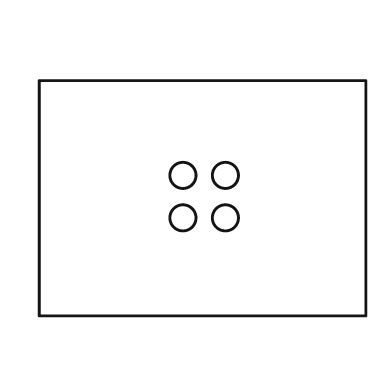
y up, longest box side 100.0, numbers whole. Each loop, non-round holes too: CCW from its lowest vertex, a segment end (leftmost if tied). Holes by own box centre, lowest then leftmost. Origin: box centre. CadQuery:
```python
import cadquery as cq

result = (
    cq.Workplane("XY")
    .moveTo(-50.0, -36.0)
    .lineTo(50.0, -36.0)
    .lineTo(50.0, 36.0)
    .lineTo(-50.0, 36.0)
    .close()
    .moveTo(-6.0, -6.0)
    .circle(4.0)
    .moveTo(7.0, -6.0)
    .circle(4.0)
    .moveTo(-6.0, 7.0)
    .circle(4.0)
    .moveTo(7.0, 7.0)
    .circle(4.0)
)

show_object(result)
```